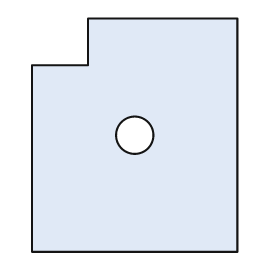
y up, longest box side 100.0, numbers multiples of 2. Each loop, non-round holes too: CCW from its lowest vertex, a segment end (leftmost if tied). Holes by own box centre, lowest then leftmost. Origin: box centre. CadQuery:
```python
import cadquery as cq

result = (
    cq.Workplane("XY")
    .moveTo(-44.0, -50.0)
    .lineTo(44.0, -50.0)
    .lineTo(44.0, 50.0)
    .lineTo(-20.0, 50.0)
    .lineTo(-20.0, 30.0)
    .lineTo(-44.0, 30.0)
    .close()
    .moveTo(0.0, 0.0)
    .circle(8.0)
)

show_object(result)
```